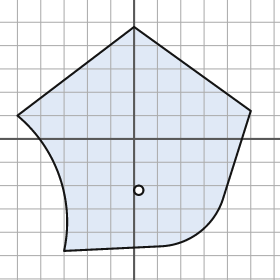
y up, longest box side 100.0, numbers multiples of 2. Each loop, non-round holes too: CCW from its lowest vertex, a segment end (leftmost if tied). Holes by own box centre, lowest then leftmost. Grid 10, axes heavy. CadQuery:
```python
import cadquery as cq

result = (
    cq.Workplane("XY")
    .moveTo(-30.0, -48.0)
    .lineTo(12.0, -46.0)
    .threePointArc((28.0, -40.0), (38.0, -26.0))
    .lineTo(50.0, 12.0)
    .lineTo(0.0, 48.0)
    .lineTo(-50.0, 10.0)
    .threePointArc((-32.0, -16.0), (-30.0, -48.0))
    .close()
    .moveTo(2.0, -22.0)
    .circle(2.0)
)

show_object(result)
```